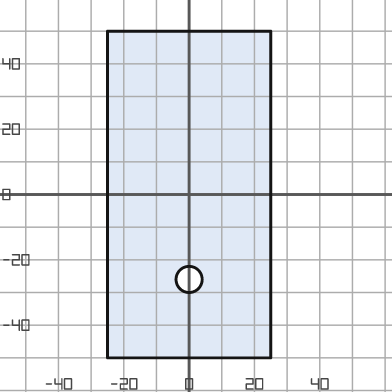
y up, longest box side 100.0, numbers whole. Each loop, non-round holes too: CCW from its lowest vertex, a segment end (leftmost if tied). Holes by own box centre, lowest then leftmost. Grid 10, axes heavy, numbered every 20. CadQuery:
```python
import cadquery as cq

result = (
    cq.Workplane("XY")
    .moveTo(-25.0, -50.0)
    .lineTo(25.0, -50.0)
    .lineTo(25.0, 50.0)
    .lineTo(-25.0, 50.0)
    .close()
    .moveTo(0.0, -26.0)
    .circle(4.0)
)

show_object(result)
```